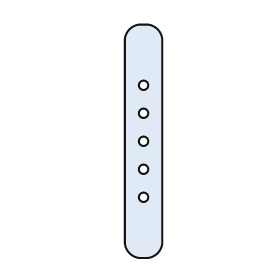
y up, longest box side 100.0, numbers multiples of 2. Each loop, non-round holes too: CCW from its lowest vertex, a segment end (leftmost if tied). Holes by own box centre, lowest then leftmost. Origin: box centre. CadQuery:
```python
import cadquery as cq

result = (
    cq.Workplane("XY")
    .moveTo(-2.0, -50.0)
    .lineTo(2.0, -50.0)
    .threePointArc((6.0, -48.0), (8.0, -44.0))
    .lineTo(8.0, 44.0)
    .threePointArc((6.0, 48.0), (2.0, 50.0))
    .lineTo(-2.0, 50.0)
    .threePointArc((-6.0, 48.0), (-8.0, 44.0))
    .lineTo(-8.0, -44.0)
    .threePointArc((-6.0, -48.0), (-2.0, -50.0))
    .close()
    .moveTo(0.0, -24.0)
    .circle(2.0)
    .moveTo(0.0, -12.0)
    .circle(2.0)
    .moveTo(0.0, 0.0)
    .circle(2.0)
    .moveTo(0.0, 12.0)
    .circle(2.0)
    .moveTo(0.0, 24.0)
    .circle(2.0)
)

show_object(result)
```